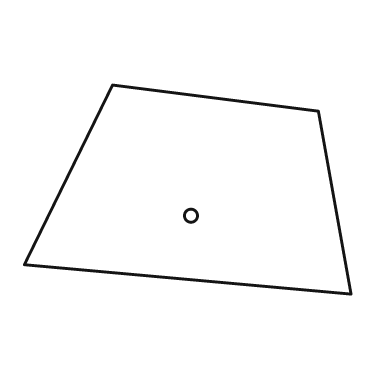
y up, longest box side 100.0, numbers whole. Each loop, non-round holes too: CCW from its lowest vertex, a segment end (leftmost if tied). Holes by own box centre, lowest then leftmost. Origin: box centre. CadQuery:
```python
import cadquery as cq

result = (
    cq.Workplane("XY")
    .moveTo(50.0, -32.0)
    .lineTo(40.0, 24.0)
    .lineTo(-23.0, 32.0)
    .lineTo(-50.0, -23.0)
    .close()
    .moveTo(1.0, -8.0)
    .circle(2.0)
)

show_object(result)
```